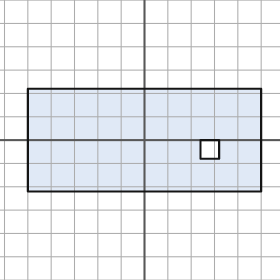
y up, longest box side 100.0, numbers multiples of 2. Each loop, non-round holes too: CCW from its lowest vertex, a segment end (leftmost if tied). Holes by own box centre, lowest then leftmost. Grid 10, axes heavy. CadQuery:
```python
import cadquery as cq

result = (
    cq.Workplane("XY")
    .moveTo(-50.0, -22.0)
    .lineTo(50.0, -22.0)
    .lineTo(50.0, 22.0)
    .lineTo(-50.0, 22.0)
    .close()
    .moveTo(24.0, -8.0)
    .lineTo(32.0, -8.0)
    .lineTo(32.0, 0.0)
    .lineTo(24.0, 0.0)
    .close()
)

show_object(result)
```